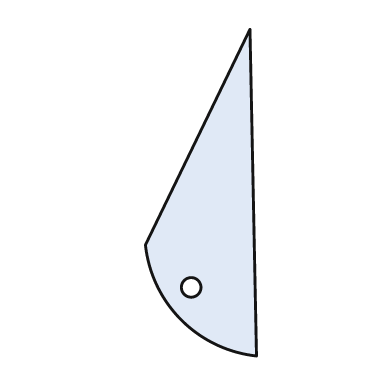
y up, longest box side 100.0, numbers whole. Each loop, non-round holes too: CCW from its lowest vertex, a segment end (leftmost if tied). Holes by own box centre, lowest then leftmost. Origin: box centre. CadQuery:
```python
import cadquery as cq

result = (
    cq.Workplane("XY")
    .moveTo(17.0, -50.0)
    .lineTo(15.0, 50.0)
    .lineTo(-17.0, -16.0)
    .threePointArc((-6.0, -39.0), (17.0, -50.0))
    .close()
    .moveTo(-3.0, -29.0)
    .circle(3.0)
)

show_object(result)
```